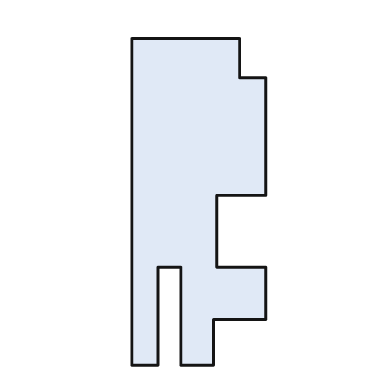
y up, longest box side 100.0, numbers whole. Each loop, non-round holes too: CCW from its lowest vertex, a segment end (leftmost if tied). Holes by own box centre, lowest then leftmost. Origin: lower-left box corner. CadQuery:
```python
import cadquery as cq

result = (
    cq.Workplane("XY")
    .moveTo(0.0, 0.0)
    .lineTo(8.0, 0.0)
    .lineTo(8.0, 30.0)
    .lineTo(15.0, 30.0)
    .lineTo(15.0, 0.0)
    .lineTo(25.0, 0.0)
    .lineTo(25.0, 14.0)
    .lineTo(41.0, 14.0)
    .lineTo(41.0, 30.0)
    .lineTo(26.0, 30.0)
    .lineTo(26.0, 52.0)
    .lineTo(41.0, 52.0)
    .lineTo(41.0, 88.0)
    .lineTo(33.0, 88.0)
    .lineTo(33.0, 100.0)
    .lineTo(0.0, 100.0)
    .close()
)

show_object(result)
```